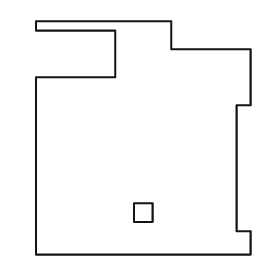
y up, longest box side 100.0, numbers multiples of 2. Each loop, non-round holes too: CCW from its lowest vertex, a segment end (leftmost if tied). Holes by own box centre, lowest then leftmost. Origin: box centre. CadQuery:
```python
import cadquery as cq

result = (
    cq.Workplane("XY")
    .moveTo(-46.0, -50.0)
    .lineTo(46.0, -50.0)
    .lineTo(46.0, -40.0)
    .lineTo(40.0, -40.0)
    .lineTo(40.0, 14.0)
    .lineTo(46.0, 14.0)
    .lineTo(46.0, 38.0)
    .lineTo(12.0, 38.0)
    .lineTo(12.0, 50.0)
    .lineTo(-46.0, 50.0)
    .lineTo(-46.0, 46.0)
    .lineTo(-12.0, 46.0)
    .lineTo(-12.0, 26.0)
    .lineTo(-46.0, 26.0)
    .close()
    .moveTo(-4.0, -36.0)
    .lineTo(4.0, -36.0)
    .lineTo(4.0, -28.0)
    .lineTo(-4.0, -28.0)
    .close()
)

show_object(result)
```